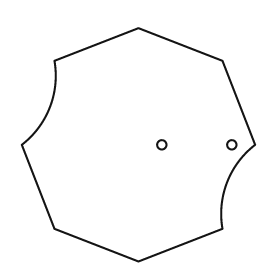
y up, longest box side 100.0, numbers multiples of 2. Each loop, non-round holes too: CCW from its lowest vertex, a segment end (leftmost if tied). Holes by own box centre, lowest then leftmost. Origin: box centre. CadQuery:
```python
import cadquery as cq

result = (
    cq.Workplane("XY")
    .moveTo(0.0, -50.0)
    .lineTo(36.0, -36.0)
    .threePointArc((38.0, -16.0), (50.0, 0.0))
    .lineTo(36.0, 36.0)
    .lineTo(0.0, 50.0)
    .lineTo(-36.0, 36.0)
    .threePointArc((-38.0, 16.0), (-50.0, 0.0))
    .lineTo(-36.0, -36.0)
    .close()
    .moveTo(10.0, 0.0)
    .circle(2.0)
    .moveTo(40.0, 0.0)
    .circle(2.0)
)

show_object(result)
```